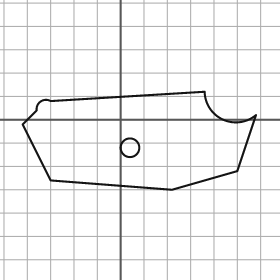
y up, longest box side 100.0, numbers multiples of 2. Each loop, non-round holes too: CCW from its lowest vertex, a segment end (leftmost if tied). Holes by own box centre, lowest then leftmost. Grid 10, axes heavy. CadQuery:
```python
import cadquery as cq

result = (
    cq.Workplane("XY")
    .moveTo(22.0, -30.0)
    .lineTo(50.0, -22.0)
    .lineTo(58.0, 2.0)
    .threePointArc((44.0, 0.0), (36.0, 12.0))
    .lineTo(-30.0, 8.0)
    .threePointArc((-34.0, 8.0), (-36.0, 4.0))
    .lineTo(-42.0, -2.0)
    .lineTo(-30.0, -26.0)
    .close()
    .moveTo(4.0, -12.0)
    .circle(4.0)
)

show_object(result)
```